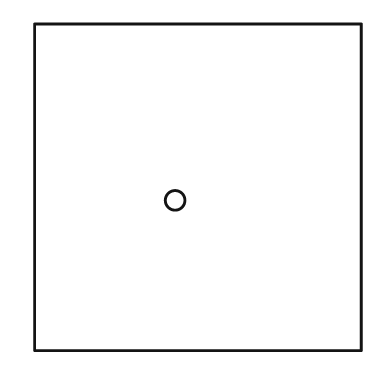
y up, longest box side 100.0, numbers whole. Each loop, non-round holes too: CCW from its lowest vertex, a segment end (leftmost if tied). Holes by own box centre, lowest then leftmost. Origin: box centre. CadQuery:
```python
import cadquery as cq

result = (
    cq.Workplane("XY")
    .moveTo(-50.0, -50.0)
    .lineTo(50.0, -50.0)
    .lineTo(50.0, 50.0)
    .lineTo(-50.0, 50.0)
    .close()
    .moveTo(-7.0, -4.0)
    .circle(3.0)
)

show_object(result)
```